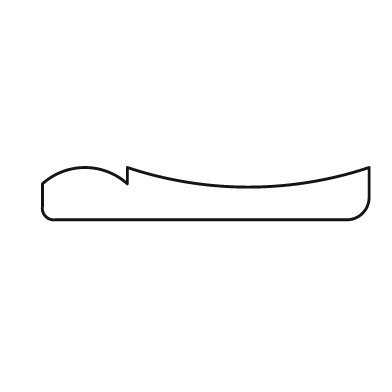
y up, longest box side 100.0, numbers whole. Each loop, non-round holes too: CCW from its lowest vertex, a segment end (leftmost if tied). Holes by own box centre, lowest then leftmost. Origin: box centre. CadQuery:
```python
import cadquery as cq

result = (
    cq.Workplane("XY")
    .moveTo(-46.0, -8.0)
    .lineTo(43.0, -8.0)
    .threePointArc((48.0, -6.0), (50.0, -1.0))
    .lineTo(50.0, 8.0)
    .threePointArc((13.0, 2.0), (-24.0, 8.0))
    .lineTo(-24.0, 3.0)
    .threePointArc((-37.0, 8.0), (-50.0, 3.0))
    .lineTo(-50.0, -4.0)
    .threePointArc((-49.0, -7.0), (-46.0, -8.0))
    .close()
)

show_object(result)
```